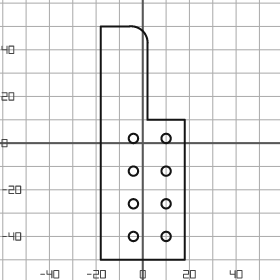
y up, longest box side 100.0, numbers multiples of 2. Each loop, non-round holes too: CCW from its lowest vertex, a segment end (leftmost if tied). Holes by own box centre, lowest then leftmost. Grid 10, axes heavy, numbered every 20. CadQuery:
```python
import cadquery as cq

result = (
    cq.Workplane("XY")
    .moveTo(-18.0, -50.0)
    .lineTo(18.0, -50.0)
    .lineTo(18.0, 10.0)
    .lineTo(2.0, 10.0)
    .lineTo(2.0, 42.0)
    .threePointArc((0.0, 48.0), (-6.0, 50.0))
    .lineTo(-18.0, 50.0)
    .close()
    .moveTo(-4.0, -40.0)
    .circle(2.0)
    .moveTo(10.0, -40.0)
    .circle(2.0)
    .moveTo(-4.0, -26.0)
    .circle(2.0)
    .moveTo(10.0, -26.0)
    .circle(2.0)
    .moveTo(-4.0, -12.0)
    .circle(2.0)
    .moveTo(10.0, -12.0)
    .circle(2.0)
    .moveTo(-4.0, 2.0)
    .circle(2.0)
    .moveTo(10.0, 2.0)
    .circle(2.0)
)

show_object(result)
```